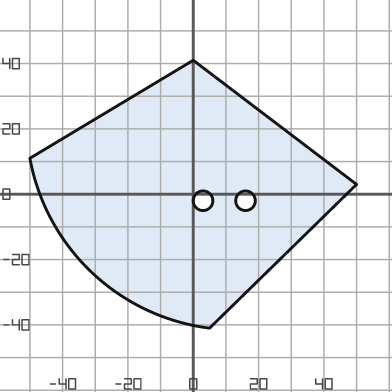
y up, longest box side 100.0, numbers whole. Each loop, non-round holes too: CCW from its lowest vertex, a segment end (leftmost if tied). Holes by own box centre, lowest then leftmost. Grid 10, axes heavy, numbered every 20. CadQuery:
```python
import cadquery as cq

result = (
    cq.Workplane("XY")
    .moveTo(5.0, -41.0)
    .lineTo(50.0, 3.0)
    .lineTo(0.0, 41.0)
    .lineTo(-50.0, 11.0)
    .threePointArc((-31.0, -24.0), (5.0, -41.0))
    .close()
    .moveTo(3.0, -2.0)
    .circle(3.0)
    .moveTo(16.0, -2.0)
    .circle(3.0)
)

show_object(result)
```